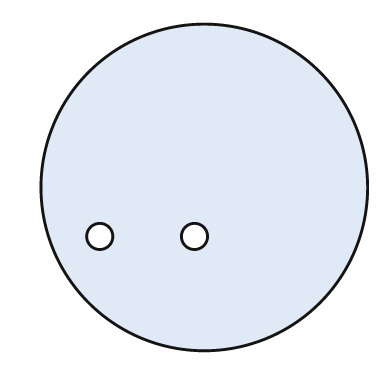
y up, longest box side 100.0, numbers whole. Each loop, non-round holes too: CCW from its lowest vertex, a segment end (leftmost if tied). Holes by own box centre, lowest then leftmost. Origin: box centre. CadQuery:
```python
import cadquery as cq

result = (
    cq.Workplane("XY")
    .moveTo(0.0, 0.0)
    .circle(50.0)
    .moveTo(-32.0, -15.0)
    .circle(4.0)
    .moveTo(-3.0, -15.0)
    .circle(4.0)
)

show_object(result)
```